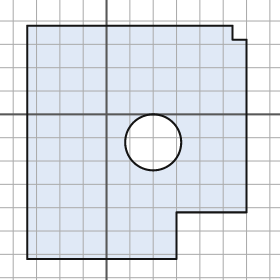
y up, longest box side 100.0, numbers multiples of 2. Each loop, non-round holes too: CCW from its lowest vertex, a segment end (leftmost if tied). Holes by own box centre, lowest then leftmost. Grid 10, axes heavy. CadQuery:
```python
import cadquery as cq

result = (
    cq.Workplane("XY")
    .moveTo(-34.0, -62.0)
    .lineTo(30.0, -62.0)
    .lineTo(30.0, -42.0)
    .lineTo(60.0, -42.0)
    .lineTo(60.0, 32.0)
    .lineTo(54.0, 32.0)
    .lineTo(54.0, 38.0)
    .lineTo(-34.0, 38.0)
    .close()
    .moveTo(20.0, -12.0)
    .circle(12.0)
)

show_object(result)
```